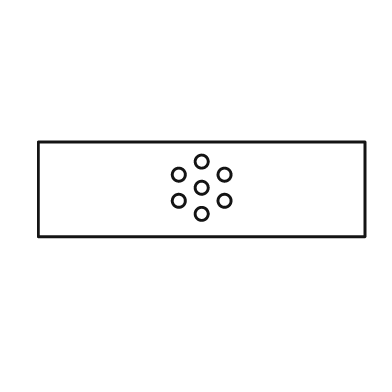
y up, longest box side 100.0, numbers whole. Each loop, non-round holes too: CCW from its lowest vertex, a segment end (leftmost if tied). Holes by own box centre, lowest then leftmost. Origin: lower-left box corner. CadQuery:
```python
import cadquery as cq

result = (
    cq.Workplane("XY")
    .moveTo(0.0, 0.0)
    .lineTo(100.0, 0.0)
    .lineTo(100.0, 29.0)
    .lineTo(0.0, 29.0)
    .close()
    .moveTo(50.0, 7.0)
    .circle(2.0)
    .moveTo(43.0, 11.0)
    .circle(2.0)
    .moveTo(57.0, 11.0)
    .circle(2.0)
    .moveTo(50.0, 15.0)
    .circle(2.0)
    .moveTo(43.0, 19.0)
    .circle(2.0)
    .moveTo(57.0, 19.0)
    .circle(2.0)
    .moveTo(50.0, 23.0)
    .circle(2.0)
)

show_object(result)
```